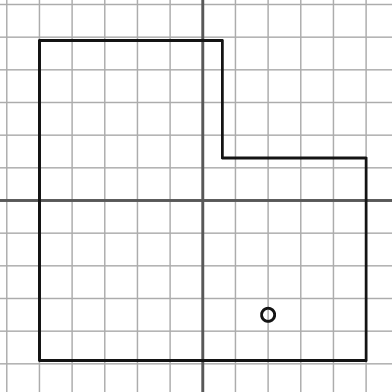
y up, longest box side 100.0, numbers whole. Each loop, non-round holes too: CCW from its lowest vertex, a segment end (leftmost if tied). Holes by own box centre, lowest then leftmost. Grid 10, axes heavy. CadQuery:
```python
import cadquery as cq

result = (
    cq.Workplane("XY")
    .moveTo(-50.0, -49.0)
    .lineTo(50.0, -49.0)
    .lineTo(50.0, 13.0)
    .lineTo(6.0, 13.0)
    .lineTo(6.0, 49.0)
    .lineTo(-50.0, 49.0)
    .close()
    .moveTo(20.0, -35.0)
    .circle(2.0)
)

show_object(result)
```